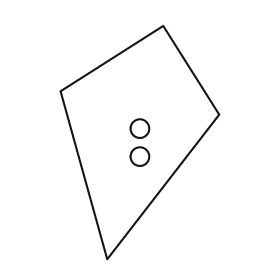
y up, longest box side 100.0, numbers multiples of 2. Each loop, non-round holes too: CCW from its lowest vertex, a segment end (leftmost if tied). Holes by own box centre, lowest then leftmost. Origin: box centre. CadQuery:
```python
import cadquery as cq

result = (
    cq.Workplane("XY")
    .moveTo(-14.0, -50.0)
    .lineTo(34.0, 12.0)
    .lineTo(10.0, 50.0)
    .lineTo(-34.0, 22.0)
    .close()
    .moveTo(0.0, -6.0)
    .circle(4.0)
    .moveTo(0.0, 6.0)
    .circle(4.0)
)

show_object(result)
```